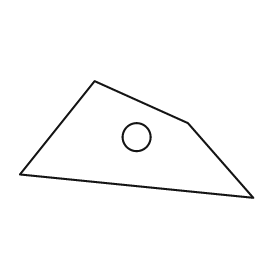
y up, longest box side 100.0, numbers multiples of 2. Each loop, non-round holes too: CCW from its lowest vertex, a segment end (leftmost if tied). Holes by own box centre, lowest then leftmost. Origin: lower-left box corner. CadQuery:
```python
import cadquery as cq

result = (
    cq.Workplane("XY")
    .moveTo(100.0, 0.0)
    .lineTo(72.0, 32.0)
    .lineTo(32.0, 50.0)
    .lineTo(0.0, 10.0)
    .close()
    .moveTo(50.0, 26.0)
    .circle(6.0)
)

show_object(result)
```